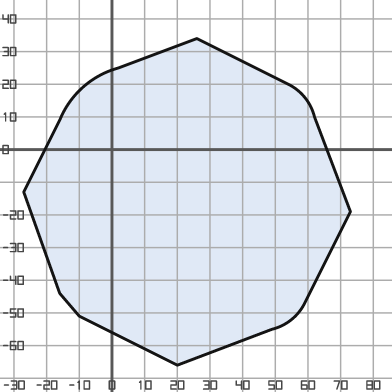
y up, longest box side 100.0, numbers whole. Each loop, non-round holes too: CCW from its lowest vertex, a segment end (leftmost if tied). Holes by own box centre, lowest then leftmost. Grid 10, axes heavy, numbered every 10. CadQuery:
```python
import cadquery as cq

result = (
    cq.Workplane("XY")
    .moveTo(20.0, -66.0)
    .lineTo(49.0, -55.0)
    .threePointArc((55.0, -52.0), (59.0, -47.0))
    .lineTo(73.0, -19.0)
    .lineTo(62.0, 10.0)
    .threePointArc((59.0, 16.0), (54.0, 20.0))
    .lineTo(26.0, 34.0)
    .lineTo(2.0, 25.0)
    .threePointArc((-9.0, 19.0), (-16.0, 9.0))
    .lineTo(-27.0, -13.0)
    .lineTo(-16.0, -44.0)
    .lineTo(-10.0, -51.0)
    .close()
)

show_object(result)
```